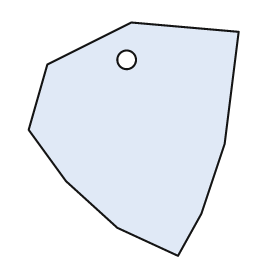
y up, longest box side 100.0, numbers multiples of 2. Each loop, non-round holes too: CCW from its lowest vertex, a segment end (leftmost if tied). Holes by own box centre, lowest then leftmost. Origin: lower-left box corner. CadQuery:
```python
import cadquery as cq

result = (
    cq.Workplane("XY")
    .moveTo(64.0, 0.0)
    .lineTo(74.0, 18.0)
    .lineTo(84.0, 48.0)
    .lineTo(90.0, 96.0)
    .lineTo(44.0, 100.0)
    .lineTo(8.0, 82.0)
    .lineTo(0.0, 54.0)
    .lineTo(16.0, 32.0)
    .lineTo(38.0, 12.0)
    .close()
    .moveTo(42.0, 84.0)
    .circle(4.0)
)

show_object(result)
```